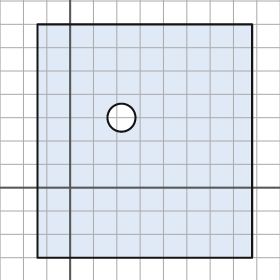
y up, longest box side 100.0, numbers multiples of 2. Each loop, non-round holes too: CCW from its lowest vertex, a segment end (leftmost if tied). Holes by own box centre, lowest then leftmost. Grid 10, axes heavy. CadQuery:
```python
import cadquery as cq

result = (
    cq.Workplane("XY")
    .moveTo(-14.0, -30.0)
    .lineTo(78.0, -30.0)
    .lineTo(78.0, 70.0)
    .lineTo(-14.0, 70.0)
    .close()
    .moveTo(22.0, 30.0)
    .circle(6.0)
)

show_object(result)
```